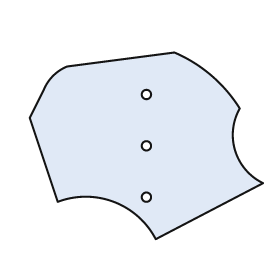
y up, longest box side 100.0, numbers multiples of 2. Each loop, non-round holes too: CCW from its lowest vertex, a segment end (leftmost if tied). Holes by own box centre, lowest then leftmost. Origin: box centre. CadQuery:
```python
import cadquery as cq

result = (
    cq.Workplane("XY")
    .moveTo(4.0, -40.0)
    .lineTo(50.0, -16.0)
    .threePointArc((38.0, -2.0), (40.0, 16.0))
    .threePointArc((28.0, 30.0), (12.0, 40.0))
    .lineTo(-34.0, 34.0)
    .threePointArc((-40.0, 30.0), (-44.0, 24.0))
    .lineTo(-50.0, 12.0)
    .lineTo(-38.0, -24.0)
    .threePointArc((-14.0, -24.0), (4.0, -40.0))
    .close()
    .moveTo(0.0, -22.0)
    .circle(2.0)
    .moveTo(0.0, 0.0)
    .circle(2.0)
    .moveTo(0.0, 22.0)
    .circle(2.0)
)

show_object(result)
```